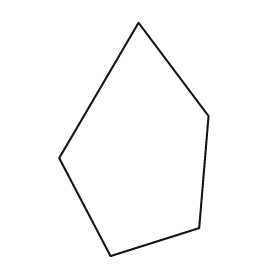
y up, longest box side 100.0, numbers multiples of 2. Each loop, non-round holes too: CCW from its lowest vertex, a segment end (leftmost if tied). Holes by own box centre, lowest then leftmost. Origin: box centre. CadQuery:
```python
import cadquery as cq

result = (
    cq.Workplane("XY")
    .moveTo(-10.0, -50.0)
    .lineTo(28.0, -38.0)
    .lineTo(32.0, 10.0)
    .lineTo(2.0, 50.0)
    .lineTo(-32.0, -8.0)
    .close()
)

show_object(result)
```